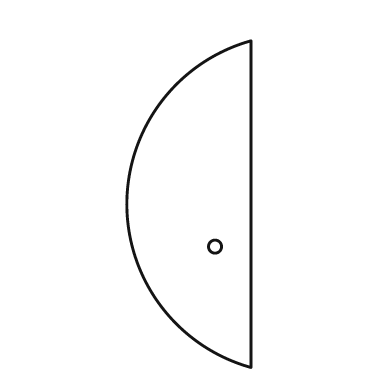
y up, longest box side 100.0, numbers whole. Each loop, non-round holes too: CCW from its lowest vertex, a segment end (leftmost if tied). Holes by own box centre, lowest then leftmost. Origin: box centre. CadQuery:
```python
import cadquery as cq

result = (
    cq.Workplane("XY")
    .moveTo(19.0, -50.0)
    .lineTo(19.0, 50.0)
    .threePointArc((-19.0, 0.0), (19.0, -50.0))
    .close()
    .moveTo(8.0, -13.0)
    .circle(2.0)
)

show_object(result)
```